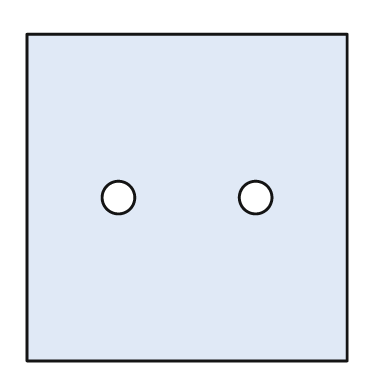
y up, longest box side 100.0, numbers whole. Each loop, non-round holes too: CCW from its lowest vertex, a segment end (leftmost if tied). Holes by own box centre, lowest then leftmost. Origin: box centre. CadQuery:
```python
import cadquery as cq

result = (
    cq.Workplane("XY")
    .moveTo(-49.0, -50.0)
    .lineTo(49.0, -50.0)
    .lineTo(49.0, 50.0)
    .lineTo(-49.0, 50.0)
    .close()
    .moveTo(-21.0, 0.0)
    .circle(5.0)
    .moveTo(21.0, 0.0)
    .circle(5.0)
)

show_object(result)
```